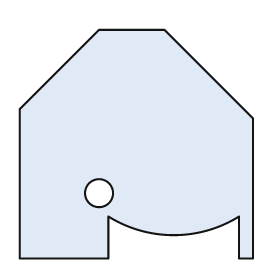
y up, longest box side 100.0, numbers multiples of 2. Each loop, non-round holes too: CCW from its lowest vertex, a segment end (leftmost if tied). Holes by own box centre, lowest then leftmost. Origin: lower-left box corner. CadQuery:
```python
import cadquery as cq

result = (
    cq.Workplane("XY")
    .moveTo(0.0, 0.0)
    .lineTo(38.0, 0.0)
    .lineTo(38.0, 18.0)
    .threePointArc((66.0, 10.0), (94.0, 18.0))
    .lineTo(94.0, 0.0)
    .lineTo(100.0, 0.0)
    .lineTo(100.0, 60.0)
    .lineTo(62.0, 98.0)
    .lineTo(34.0, 98.0)
    .lineTo(0.0, 64.0)
    .close()
    .moveTo(34.0, 28.0)
    .circle(6.0)
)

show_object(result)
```